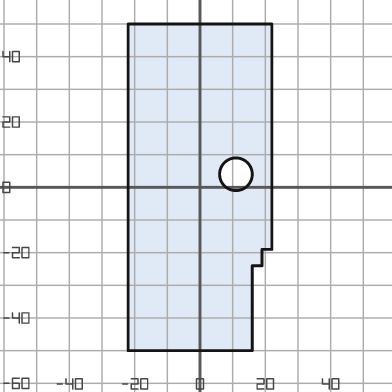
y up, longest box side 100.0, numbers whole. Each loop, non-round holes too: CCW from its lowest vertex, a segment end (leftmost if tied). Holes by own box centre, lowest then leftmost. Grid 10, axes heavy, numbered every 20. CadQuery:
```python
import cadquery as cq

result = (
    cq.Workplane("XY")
    .moveTo(-22.0, -50.0)
    .lineTo(16.0, -50.0)
    .lineTo(16.0, -24.0)
    .lineTo(19.0, -24.0)
    .lineTo(19.0, -19.0)
    .lineTo(22.0, -19.0)
    .lineTo(22.0, 50.0)
    .lineTo(-22.0, 50.0)
    .close()
    .moveTo(11.0, 4.0)
    .circle(5.0)
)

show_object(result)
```